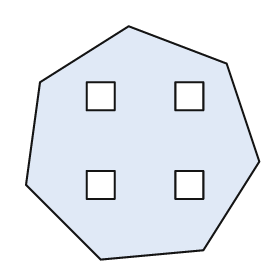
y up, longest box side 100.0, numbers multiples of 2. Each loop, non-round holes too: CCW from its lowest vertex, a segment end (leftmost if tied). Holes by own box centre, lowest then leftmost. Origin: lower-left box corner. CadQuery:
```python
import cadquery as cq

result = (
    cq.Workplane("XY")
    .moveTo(32.0, 0.0)
    .lineTo(76.0, 4.0)
    .lineTo(100.0, 42.0)
    .lineTo(86.0, 84.0)
    .lineTo(44.0, 100.0)
    .lineTo(6.0, 76.0)
    .lineTo(0.0, 32.0)
    .close()
    .moveTo(26.0, 26.0)
    .lineTo(38.0, 26.0)
    .lineTo(38.0, 38.0)
    .lineTo(26.0, 38.0)
    .close()
    .moveTo(64.0, 26.0)
    .lineTo(76.0, 26.0)
    .lineTo(76.0, 38.0)
    .lineTo(64.0, 38.0)
    .close()
    .moveTo(26.0, 64.0)
    .lineTo(38.0, 64.0)
    .lineTo(38.0, 76.0)
    .lineTo(26.0, 76.0)
    .close()
    .moveTo(64.0, 64.0)
    .lineTo(76.0, 64.0)
    .lineTo(76.0, 76.0)
    .lineTo(64.0, 76.0)
    .close()
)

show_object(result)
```